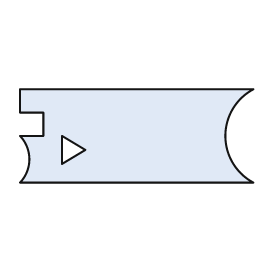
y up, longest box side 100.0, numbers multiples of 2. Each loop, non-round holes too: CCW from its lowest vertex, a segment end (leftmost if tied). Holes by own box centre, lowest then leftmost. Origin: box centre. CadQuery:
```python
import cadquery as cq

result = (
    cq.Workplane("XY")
    .moveTo(-50.0, -20.0)
    .lineTo(50.0, -20.0)
    .threePointArc((38.0, 0.0), (50.0, 20.0))
    .lineTo(-50.0, 20.0)
    .lineTo(-50.0, 10.0)
    .lineTo(-40.0, 10.0)
    .lineTo(-40.0, 0.0)
    .lineTo(-50.0, 0.0)
    .threePointArc((-46.0, -10.0), (-50.0, -20.0))
    .close()
    .moveTo(-32.0, -12.0)
    .lineTo(-22.0, -6.0)
    .lineTo(-32.0, 0.0)
    .close()
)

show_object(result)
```